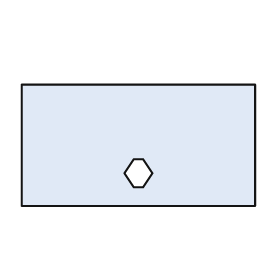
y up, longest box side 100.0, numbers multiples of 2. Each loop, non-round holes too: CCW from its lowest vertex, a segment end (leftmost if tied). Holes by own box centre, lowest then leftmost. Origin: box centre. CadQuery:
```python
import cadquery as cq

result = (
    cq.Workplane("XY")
    .moveTo(-50.0, -26.0)
    .lineTo(50.0, -26.0)
    .lineTo(50.0, 26.0)
    .lineTo(-50.0, 26.0)
    .close()
    .moveTo(-2.0, -18.0)
    .lineTo(2.0, -18.0)
    .lineTo(6.0, -12.0)
    .lineTo(2.0, -6.0)
    .lineTo(-2.0, -6.0)
    .lineTo(-6.0, -12.0)
    .close()
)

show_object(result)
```